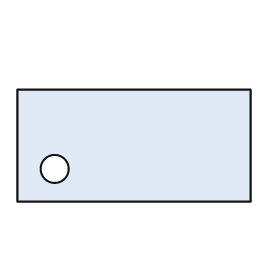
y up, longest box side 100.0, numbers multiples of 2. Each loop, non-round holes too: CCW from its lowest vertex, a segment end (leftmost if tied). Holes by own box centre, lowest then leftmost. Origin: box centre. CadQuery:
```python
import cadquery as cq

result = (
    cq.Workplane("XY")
    .moveTo(-50.0, -24.0)
    .lineTo(50.0, -24.0)
    .lineTo(50.0, 24.0)
    .lineTo(-50.0, 24.0)
    .close()
    .moveTo(-34.0, -10.0)
    .circle(6.0)
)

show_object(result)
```